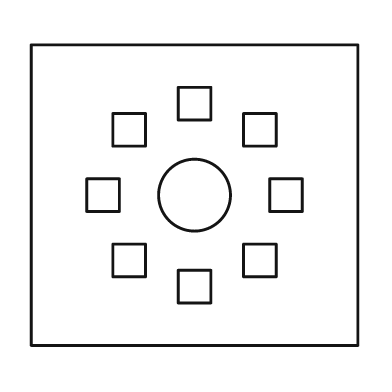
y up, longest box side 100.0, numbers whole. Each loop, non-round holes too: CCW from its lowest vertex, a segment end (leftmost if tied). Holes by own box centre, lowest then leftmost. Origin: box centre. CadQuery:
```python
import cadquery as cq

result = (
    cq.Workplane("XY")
    .moveTo(-50.0, -46.0)
    .lineTo(50.0, -46.0)
    .lineTo(50.0, 46.0)
    .lineTo(-50.0, 46.0)
    .close()
    .moveTo(-5.0, -33.0)
    .lineTo(5.0, -33.0)
    .lineTo(5.0, -23.0)
    .lineTo(-5.0, -23.0)
    .close()
    .moveTo(-25.0, -25.0)
    .lineTo(-15.0, -25.0)
    .lineTo(-15.0, -15.0)
    .lineTo(-25.0, -15.0)
    .close()
    .moveTo(15.0, -25.0)
    .lineTo(25.0, -25.0)
    .lineTo(25.0, -15.0)
    .lineTo(15.0, -15.0)
    .close()
    .moveTo(-33.0, -5.0)
    .lineTo(-23.0, -5.0)
    .lineTo(-23.0, 5.0)
    .lineTo(-33.0, 5.0)
    .close()
    .moveTo(0.0, 0.0)
    .circle(11.0)
    .moveTo(23.0, -5.0)
    .lineTo(33.0, -5.0)
    .lineTo(33.0, 5.0)
    .lineTo(23.0, 5.0)
    .close()
    .moveTo(-25.0, 15.0)
    .lineTo(-15.0, 15.0)
    .lineTo(-15.0, 25.0)
    .lineTo(-25.0, 25.0)
    .close()
    .moveTo(15.0, 15.0)
    .lineTo(25.0, 15.0)
    .lineTo(25.0, 25.0)
    .lineTo(15.0, 25.0)
    .close()
    .moveTo(-5.0, 23.0)
    .lineTo(5.0, 23.0)
    .lineTo(5.0, 33.0)
    .lineTo(-5.0, 33.0)
    .close()
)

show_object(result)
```